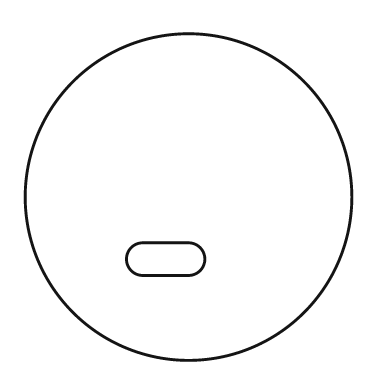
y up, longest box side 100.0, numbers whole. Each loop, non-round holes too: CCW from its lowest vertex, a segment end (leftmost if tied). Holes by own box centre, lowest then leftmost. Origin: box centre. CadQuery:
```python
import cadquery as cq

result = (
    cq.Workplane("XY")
    .moveTo(0.0, 0.0)
    .circle(50.0)
    .moveTo(-14.0, -24.0)
    .lineTo(0.0, -24.0)
    .threePointArc((5.0, -19.0), (0.0, -14.0))
    .lineTo(-14.0, -14.0)
    .threePointArc((-19.0, -19.0), (-14.0, -24.0))
    .close()
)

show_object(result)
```